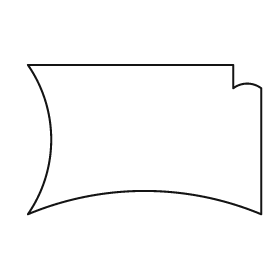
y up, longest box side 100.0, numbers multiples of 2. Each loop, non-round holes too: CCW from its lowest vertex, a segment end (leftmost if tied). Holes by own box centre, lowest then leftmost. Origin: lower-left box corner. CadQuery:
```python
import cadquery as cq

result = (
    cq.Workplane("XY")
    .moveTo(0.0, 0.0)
    .threePointArc((50.0, 10.0), (100.0, 0.0))
    .lineTo(100.0, 54.0)
    .threePointArc((94.0, 56.0), (88.0, 54.0))
    .lineTo(88.0, 64.0)
    .lineTo(0.0, 64.0)
    .threePointArc((10.0, 32.0), (0.0, 0.0))
    .close()
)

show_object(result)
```